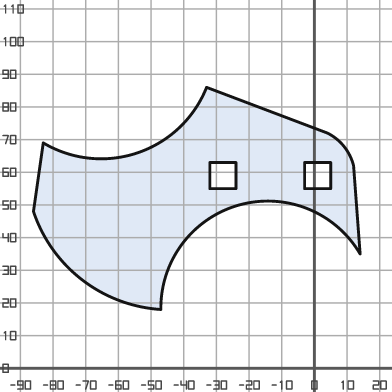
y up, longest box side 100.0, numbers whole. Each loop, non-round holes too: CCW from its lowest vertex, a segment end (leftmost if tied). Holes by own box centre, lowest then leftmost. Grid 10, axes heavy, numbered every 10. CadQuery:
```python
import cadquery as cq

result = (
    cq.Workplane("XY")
    .moveTo(-47.0, 18.0)
    .threePointArc((-23.0, 50.0), (14.0, 35.0))
    .lineTo(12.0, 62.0)
    .threePointArc((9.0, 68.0), (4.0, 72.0))
    .lineTo(-33.0, 86.0)
    .threePointArc((-54.0, 66.0), (-83.0, 69.0))
    .lineTo(-86.0, 48.0)
    .threePointArc((-71.0, 27.0), (-47.0, 18.0))
    .close()
    .moveTo(-32.0, 55.0)
    .lineTo(-24.0, 55.0)
    .lineTo(-24.0, 63.0)
    .lineTo(-32.0, 63.0)
    .close()
    .moveTo(-3.0, 55.0)
    .lineTo(5.0, 55.0)
    .lineTo(5.0, 63.0)
    .lineTo(-3.0, 63.0)
    .close()
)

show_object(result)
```